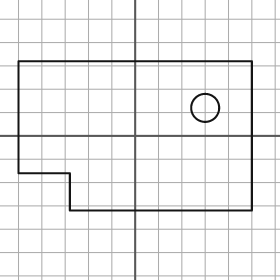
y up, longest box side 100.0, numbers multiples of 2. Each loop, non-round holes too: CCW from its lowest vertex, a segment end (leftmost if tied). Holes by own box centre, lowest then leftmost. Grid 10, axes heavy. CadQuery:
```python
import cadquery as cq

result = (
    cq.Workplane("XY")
    .moveTo(-28.0, -32.0)
    .lineTo(50.0, -32.0)
    .lineTo(50.0, 32.0)
    .lineTo(-50.0, 32.0)
    .lineTo(-50.0, -16.0)
    .lineTo(-28.0, -16.0)
    .close()
    .moveTo(30.0, 12.0)
    .circle(6.0)
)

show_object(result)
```